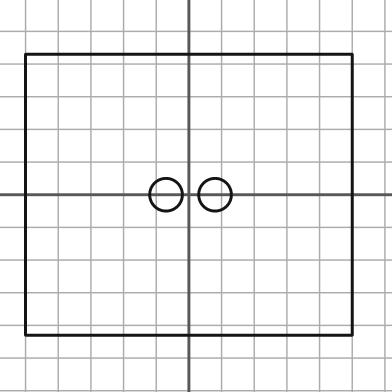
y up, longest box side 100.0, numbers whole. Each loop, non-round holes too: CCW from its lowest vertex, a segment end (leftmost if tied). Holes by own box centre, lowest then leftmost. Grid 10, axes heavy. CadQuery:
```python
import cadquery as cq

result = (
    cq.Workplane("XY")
    .moveTo(-50.0, -43.0)
    .lineTo(50.0, -43.0)
    .lineTo(50.0, 43.0)
    .lineTo(-50.0, 43.0)
    .close()
    .moveTo(-7.0, 0.0)
    .circle(5.0)
    .moveTo(8.0, 0.0)
    .circle(5.0)
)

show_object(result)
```